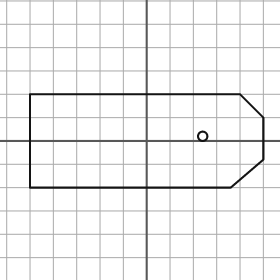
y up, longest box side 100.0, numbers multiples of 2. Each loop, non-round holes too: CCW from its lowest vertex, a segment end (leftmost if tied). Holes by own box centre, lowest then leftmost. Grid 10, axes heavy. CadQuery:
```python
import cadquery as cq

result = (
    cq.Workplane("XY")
    .moveTo(-50.0, -20.0)
    .lineTo(36.0, -20.0)
    .lineTo(50.0, -8.0)
    .lineTo(50.0, 10.0)
    .lineTo(40.0, 20.0)
    .lineTo(-50.0, 20.0)
    .close()
    .moveTo(24.0, 2.0)
    .circle(2.0)
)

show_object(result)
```